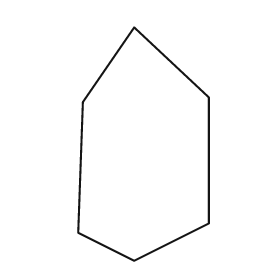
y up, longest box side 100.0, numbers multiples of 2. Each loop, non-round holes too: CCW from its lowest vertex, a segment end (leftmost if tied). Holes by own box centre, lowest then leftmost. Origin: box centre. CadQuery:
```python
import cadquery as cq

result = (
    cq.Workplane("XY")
    .moveTo(-4.0, -50.0)
    .lineTo(28.0, -34.0)
    .lineTo(28.0, 20.0)
    .lineTo(-4.0, 50.0)
    .lineTo(-26.0, 18.0)
    .lineTo(-28.0, -38.0)
    .close()
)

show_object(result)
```